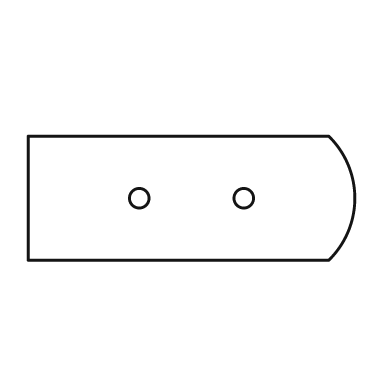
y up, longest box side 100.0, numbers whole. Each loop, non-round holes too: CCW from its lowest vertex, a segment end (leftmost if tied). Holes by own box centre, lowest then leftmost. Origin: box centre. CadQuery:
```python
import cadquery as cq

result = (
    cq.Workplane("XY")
    .moveTo(-50.0, -19.0)
    .lineTo(42.0, -19.0)
    .threePointArc((50.0, 0.0), (42.0, 19.0))
    .lineTo(-50.0, 19.0)
    .close()
    .moveTo(-16.0, 0.0)
    .circle(3.0)
    .moveTo(16.0, 0.0)
    .circle(3.0)
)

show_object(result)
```